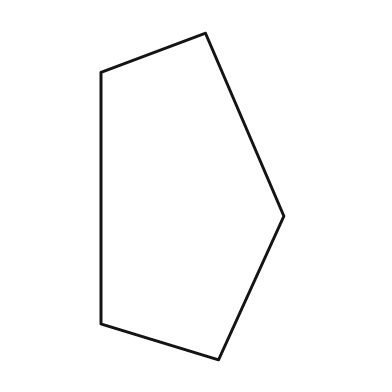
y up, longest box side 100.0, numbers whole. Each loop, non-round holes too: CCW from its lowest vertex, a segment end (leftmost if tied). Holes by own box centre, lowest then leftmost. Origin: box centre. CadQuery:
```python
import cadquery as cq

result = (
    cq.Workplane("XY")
    .moveTo(8.0, -50.0)
    .lineTo(28.0, -6.0)
    .lineTo(4.0, 50.0)
    .lineTo(-28.0, 38.0)
    .lineTo(-28.0, -39.0)
    .close()
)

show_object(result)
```